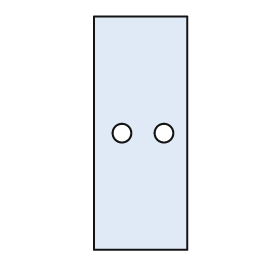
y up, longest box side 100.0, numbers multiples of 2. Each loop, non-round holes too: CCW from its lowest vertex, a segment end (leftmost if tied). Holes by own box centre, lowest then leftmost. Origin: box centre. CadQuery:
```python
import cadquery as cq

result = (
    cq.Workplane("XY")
    .moveTo(-20.0, -50.0)
    .lineTo(20.0, -50.0)
    .lineTo(20.0, 50.0)
    .lineTo(-20.0, 50.0)
    .close()
    .moveTo(-8.0, 0.0)
    .circle(4.0)
    .moveTo(10.0, 0.0)
    .circle(4.0)
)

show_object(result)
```